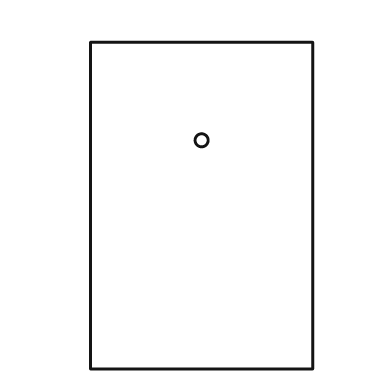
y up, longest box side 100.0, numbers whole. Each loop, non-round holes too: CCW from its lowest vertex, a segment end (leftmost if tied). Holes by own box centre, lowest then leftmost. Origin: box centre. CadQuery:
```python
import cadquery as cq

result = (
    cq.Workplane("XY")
    .moveTo(-34.0, -50.0)
    .lineTo(34.0, -50.0)
    .lineTo(34.0, 50.0)
    .lineTo(-34.0, 50.0)
    .close()
    .moveTo(0.0, 20.0)
    .circle(2.0)
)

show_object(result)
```